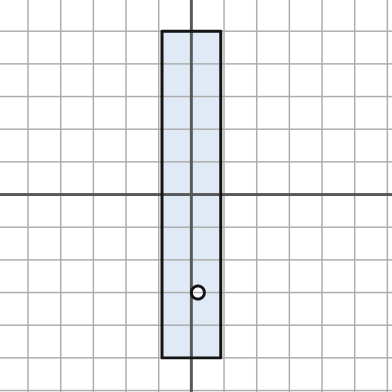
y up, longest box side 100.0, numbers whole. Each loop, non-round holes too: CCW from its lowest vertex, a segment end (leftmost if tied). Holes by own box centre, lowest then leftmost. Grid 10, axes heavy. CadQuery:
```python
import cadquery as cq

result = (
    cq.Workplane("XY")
    .moveTo(-9.0, -50.0)
    .lineTo(9.0, -50.0)
    .lineTo(9.0, 50.0)
    .lineTo(-9.0, 50.0)
    .close()
    .moveTo(2.0, -30.0)
    .circle(2.0)
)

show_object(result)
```